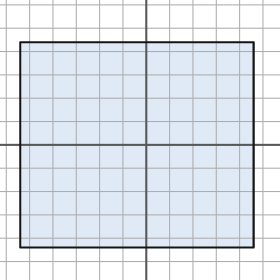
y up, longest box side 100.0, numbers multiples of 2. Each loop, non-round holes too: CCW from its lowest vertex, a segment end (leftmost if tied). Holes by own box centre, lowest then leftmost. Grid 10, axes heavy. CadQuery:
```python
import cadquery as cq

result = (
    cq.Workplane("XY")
    .moveTo(-54.0, -44.0)
    .lineTo(46.0, -44.0)
    .lineTo(46.0, 44.0)
    .lineTo(-54.0, 44.0)
    .close()
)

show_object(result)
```